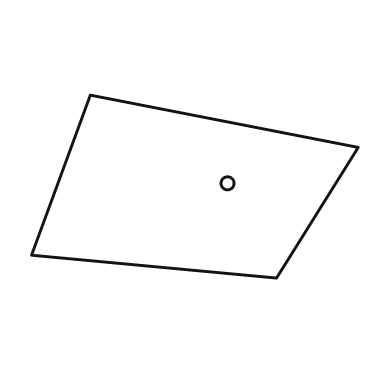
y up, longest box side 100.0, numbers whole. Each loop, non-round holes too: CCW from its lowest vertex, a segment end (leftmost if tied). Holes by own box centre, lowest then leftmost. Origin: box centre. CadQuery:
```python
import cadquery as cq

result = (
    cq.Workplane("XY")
    .moveTo(25.0, -28.0)
    .lineTo(50.0, 12.0)
    .lineTo(-32.0, 28.0)
    .lineTo(-50.0, -21.0)
    .close()
    .moveTo(10.0, 1.0)
    .circle(2.0)
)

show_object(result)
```